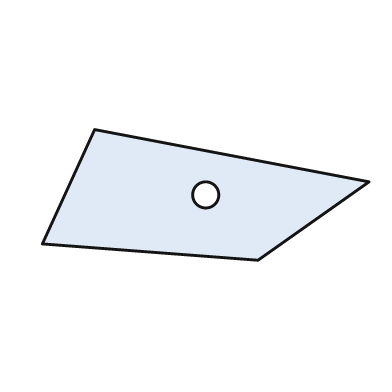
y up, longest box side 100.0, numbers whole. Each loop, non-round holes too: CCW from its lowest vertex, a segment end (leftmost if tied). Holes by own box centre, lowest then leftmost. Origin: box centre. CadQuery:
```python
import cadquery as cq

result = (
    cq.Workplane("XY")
    .moveTo(16.0, -20.0)
    .lineTo(50.0, 4.0)
    .lineTo(-34.0, 20.0)
    .lineTo(-50.0, -15.0)
    .close()
    .moveTo(0.0, 0.0)
    .circle(4.0)
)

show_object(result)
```